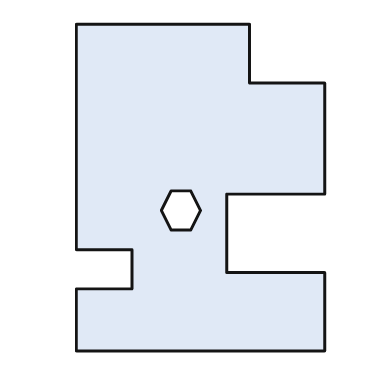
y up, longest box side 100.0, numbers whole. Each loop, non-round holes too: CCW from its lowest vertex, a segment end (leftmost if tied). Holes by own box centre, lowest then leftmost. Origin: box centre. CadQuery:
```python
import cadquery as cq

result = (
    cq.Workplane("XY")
    .moveTo(-38.0, -50.0)
    .lineTo(38.0, -50.0)
    .lineTo(38.0, -26.0)
    .lineTo(8.0, -26.0)
    .lineTo(8.0, -2.0)
    .lineTo(38.0, -2.0)
    .lineTo(38.0, 32.0)
    .lineTo(15.0, 32.0)
    .lineTo(15.0, 50.0)
    .lineTo(-38.0, 50.0)
    .lineTo(-38.0, -19.0)
    .lineTo(-21.0, -19.0)
    .lineTo(-21.0, -31.0)
    .lineTo(-38.0, -31.0)
    .close()
    .moveTo(-9.0, -13.0)
    .lineTo(-3.0, -13.0)
    .lineTo(0.0, -7.0)
    .lineTo(-3.0, -1.0)
    .lineTo(-9.0, -1.0)
    .lineTo(-12.0, -7.0)
    .close()
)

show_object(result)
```